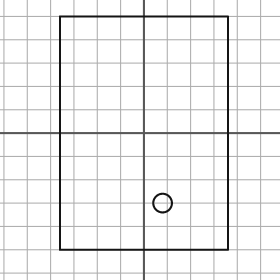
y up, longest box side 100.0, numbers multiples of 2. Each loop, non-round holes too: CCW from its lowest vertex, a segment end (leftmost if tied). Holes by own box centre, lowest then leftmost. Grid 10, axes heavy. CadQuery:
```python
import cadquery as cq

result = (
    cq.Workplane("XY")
    .moveTo(-36.0, -50.0)
    .lineTo(36.0, -50.0)
    .lineTo(36.0, 50.0)
    .lineTo(-36.0, 50.0)
    .close()
    .moveTo(8.0, -30.0)
    .circle(4.0)
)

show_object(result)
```